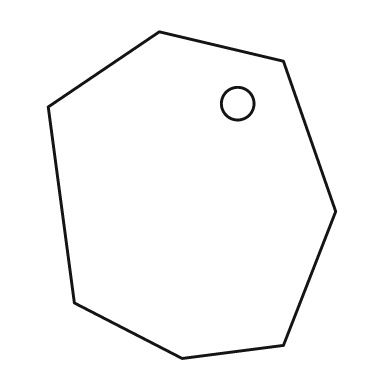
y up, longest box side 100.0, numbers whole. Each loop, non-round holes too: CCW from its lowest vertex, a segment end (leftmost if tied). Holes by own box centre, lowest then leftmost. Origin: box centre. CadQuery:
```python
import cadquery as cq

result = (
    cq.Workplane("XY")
    .moveTo(-3.0, -50.0)
    .lineTo(28.0, -46.0)
    .lineTo(44.0, -5.0)
    .lineTo(28.0, 41.0)
    .lineTo(-10.0, 50.0)
    .lineTo(-44.0, 27.0)
    .lineTo(-36.0, -33.0)
    .close()
    .moveTo(14.0, 28.0)
    .circle(5.0)
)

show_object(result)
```